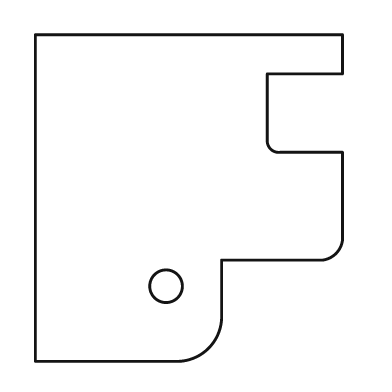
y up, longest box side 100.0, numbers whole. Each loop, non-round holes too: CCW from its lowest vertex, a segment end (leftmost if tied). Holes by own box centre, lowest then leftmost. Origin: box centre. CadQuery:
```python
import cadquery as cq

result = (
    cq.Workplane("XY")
    .moveTo(-47.0, -50.0)
    .lineTo(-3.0, -50.0)
    .threePointArc((6.0, -46.0), (10.0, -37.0))
    .lineTo(10.0, -19.0)
    .lineTo(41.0, -19.0)
    .threePointArc((45.0, -17.0), (47.0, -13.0))
    .lineTo(47.0, 14.0)
    .lineTo(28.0, 14.0)
    .threePointArc((25.0, 15.0), (24.0, 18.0))
    .lineTo(24.0, 38.0)
    .lineTo(47.0, 38.0)
    .lineTo(47.0, 50.0)
    .lineTo(-47.0, 50.0)
    .close()
    .moveTo(-7.0, -27.0)
    .circle(5.0)
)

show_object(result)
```